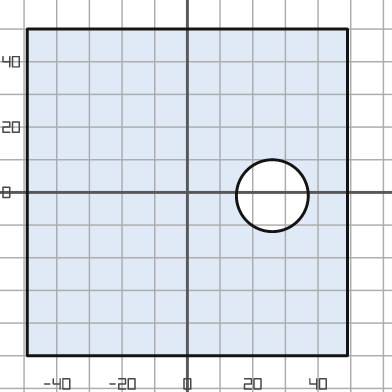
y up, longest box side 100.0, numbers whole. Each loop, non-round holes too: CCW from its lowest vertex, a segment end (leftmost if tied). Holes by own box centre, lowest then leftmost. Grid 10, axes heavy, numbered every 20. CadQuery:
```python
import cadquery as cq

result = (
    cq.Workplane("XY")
    .moveTo(-49.0, -50.0)
    .lineTo(49.0, -50.0)
    .lineTo(49.0, 50.0)
    .lineTo(-49.0, 50.0)
    .close()
    .moveTo(26.0, -1.0)
    .circle(11.0)
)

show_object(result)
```